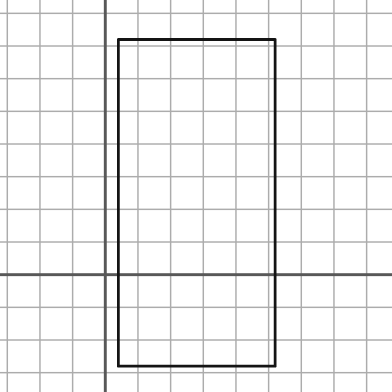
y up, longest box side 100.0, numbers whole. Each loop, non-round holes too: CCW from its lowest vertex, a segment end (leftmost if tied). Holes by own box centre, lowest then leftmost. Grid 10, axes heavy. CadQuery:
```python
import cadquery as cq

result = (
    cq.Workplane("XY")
    .moveTo(4.0, -28.0)
    .lineTo(52.0, -28.0)
    .lineTo(52.0, 72.0)
    .lineTo(4.0, 72.0)
    .close()
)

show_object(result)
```